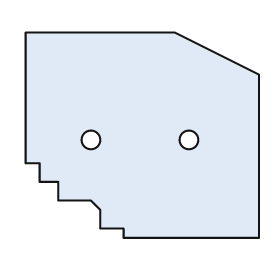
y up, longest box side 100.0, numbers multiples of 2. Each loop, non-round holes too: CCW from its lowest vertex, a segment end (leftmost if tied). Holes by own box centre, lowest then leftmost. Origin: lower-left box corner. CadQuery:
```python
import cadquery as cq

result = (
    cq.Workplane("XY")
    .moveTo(42.0, 0.0)
    .lineTo(100.0, 0.0)
    .lineTo(100.0, 70.0)
    .lineTo(64.0, 88.0)
    .lineTo(0.0, 88.0)
    .lineTo(0.0, 32.0)
    .lineTo(6.0, 32.0)
    .lineTo(6.0, 24.0)
    .lineTo(14.0, 24.0)
    .lineTo(14.0, 16.0)
    .lineTo(28.0, 16.0)
    .lineTo(32.0, 12.0)
    .lineTo(32.0, 4.0)
    .lineTo(42.0, 4.0)
    .close()
    .moveTo(28.0, 42.0)
    .circle(4.0)
    .moveTo(70.0, 42.0)
    .circle(4.0)
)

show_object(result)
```